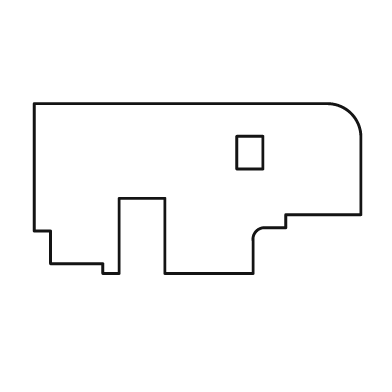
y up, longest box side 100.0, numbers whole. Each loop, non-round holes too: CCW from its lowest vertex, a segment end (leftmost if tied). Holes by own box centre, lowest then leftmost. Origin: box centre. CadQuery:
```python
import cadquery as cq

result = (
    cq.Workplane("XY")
    .moveTo(-29.0, -26.0)
    .lineTo(-24.0, -26.0)
    .lineTo(-24.0, -3.0)
    .lineTo(-10.0, -3.0)
    .lineTo(-10.0, -26.0)
    .lineTo(17.0, -26.0)
    .lineTo(17.0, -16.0)
    .threePointArc((18.0, -13.0), (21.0, -12.0))
    .lineTo(27.0, -12.0)
    .lineTo(27.0, -8.0)
    .lineTo(50.0, -8.0)
    .lineTo(50.0, 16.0)
    .threePointArc((47.0, 23.0), (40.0, 26.0))
    .lineTo(-50.0, 26.0)
    .lineTo(-50.0, -13.0)
    .lineTo(-45.0, -13.0)
    .lineTo(-45.0, -23.0)
    .lineTo(-29.0, -23.0)
    .close()
    .moveTo(12.0, 6.0)
    .lineTo(20.0, 6.0)
    .lineTo(20.0, 16.0)
    .lineTo(12.0, 16.0)
    .close()
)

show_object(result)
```